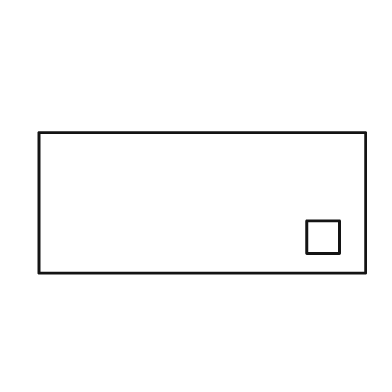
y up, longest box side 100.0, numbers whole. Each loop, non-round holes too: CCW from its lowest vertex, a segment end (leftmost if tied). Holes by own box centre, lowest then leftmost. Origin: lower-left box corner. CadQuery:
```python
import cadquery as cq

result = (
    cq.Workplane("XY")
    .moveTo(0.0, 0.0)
    .lineTo(100.0, 0.0)
    .lineTo(100.0, 43.0)
    .lineTo(0.0, 43.0)
    .close()
    .moveTo(82.0, 6.0)
    .lineTo(92.0, 6.0)
    .lineTo(92.0, 16.0)
    .lineTo(82.0, 16.0)
    .close()
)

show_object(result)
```